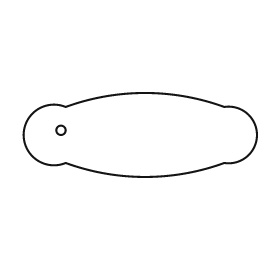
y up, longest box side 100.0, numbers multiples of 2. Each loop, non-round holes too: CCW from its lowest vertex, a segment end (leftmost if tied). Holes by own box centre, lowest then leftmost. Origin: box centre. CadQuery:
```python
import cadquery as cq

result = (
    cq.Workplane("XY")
    .moveTo(-32.0, -12.0)
    .threePointArc((2.0, -18.0), (36.0, -12.0))
    .threePointArc((50.0, 0.0), (36.0, 12.0))
    .threePointArc((2.0, 18.0), (-32.0, 12.0))
    .threePointArc((-50.0, 0.0), (-32.0, -12.0))
    .close()
    .moveTo(-34.0, 2.0)
    .circle(2.0)
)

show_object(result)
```